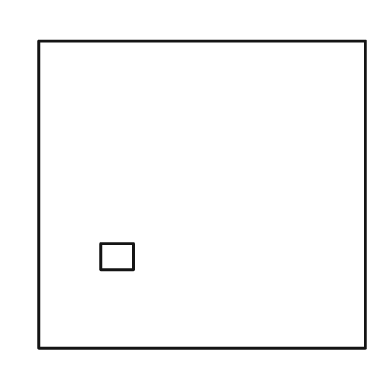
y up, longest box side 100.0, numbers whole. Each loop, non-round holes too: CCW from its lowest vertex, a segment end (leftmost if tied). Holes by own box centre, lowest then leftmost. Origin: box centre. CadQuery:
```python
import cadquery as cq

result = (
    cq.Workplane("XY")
    .moveTo(-50.0, -47.0)
    .lineTo(50.0, -47.0)
    .lineTo(50.0, 47.0)
    .lineTo(-50.0, 47.0)
    .close()
    .moveTo(-31.0, -23.0)
    .lineTo(-21.0, -23.0)
    .lineTo(-21.0, -15.0)
    .lineTo(-31.0, -15.0)
    .close()
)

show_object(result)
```